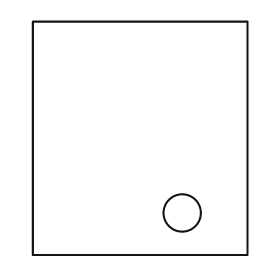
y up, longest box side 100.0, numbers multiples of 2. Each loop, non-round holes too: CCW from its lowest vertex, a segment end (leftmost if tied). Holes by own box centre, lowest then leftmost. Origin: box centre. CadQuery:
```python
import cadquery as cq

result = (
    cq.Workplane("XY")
    .moveTo(-46.0, -50.0)
    .lineTo(46.0, -50.0)
    .lineTo(46.0, 50.0)
    .lineTo(-46.0, 50.0)
    .close()
    .moveTo(18.0, -32.0)
    .circle(8.0)
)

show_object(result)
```